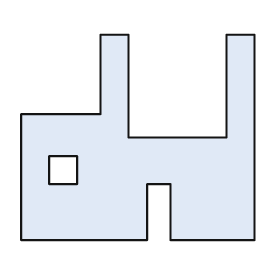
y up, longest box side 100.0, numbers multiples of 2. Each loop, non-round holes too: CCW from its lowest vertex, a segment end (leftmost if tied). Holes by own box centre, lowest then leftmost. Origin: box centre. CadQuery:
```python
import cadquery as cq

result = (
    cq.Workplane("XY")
    .moveTo(-50.0, -44.0)
    .lineTo(4.0, -44.0)
    .lineTo(4.0, -20.0)
    .lineTo(14.0, -20.0)
    .lineTo(14.0, -44.0)
    .lineTo(50.0, -44.0)
    .lineTo(50.0, 44.0)
    .lineTo(38.0, 44.0)
    .lineTo(38.0, 0.0)
    .lineTo(-4.0, 0.0)
    .lineTo(-4.0, 44.0)
    .lineTo(-16.0, 44.0)
    .lineTo(-16.0, 10.0)
    .lineTo(-50.0, 10.0)
    .close()
    .moveTo(-38.0, -20.0)
    .lineTo(-26.0, -20.0)
    .lineTo(-26.0, -8.0)
    .lineTo(-38.0, -8.0)
    .close()
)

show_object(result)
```